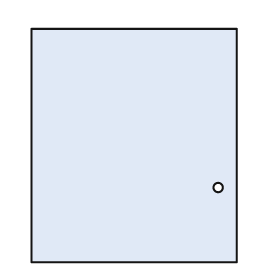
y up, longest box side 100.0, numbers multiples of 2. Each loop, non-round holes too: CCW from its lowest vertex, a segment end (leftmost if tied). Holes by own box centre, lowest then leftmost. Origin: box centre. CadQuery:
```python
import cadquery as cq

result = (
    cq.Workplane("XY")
    .moveTo(-44.0, -50.0)
    .lineTo(44.0, -50.0)
    .lineTo(44.0, 50.0)
    .lineTo(-44.0, 50.0)
    .close()
    .moveTo(36.0, -18.0)
    .circle(2.0)
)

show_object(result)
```